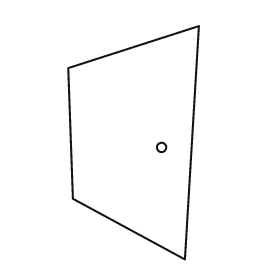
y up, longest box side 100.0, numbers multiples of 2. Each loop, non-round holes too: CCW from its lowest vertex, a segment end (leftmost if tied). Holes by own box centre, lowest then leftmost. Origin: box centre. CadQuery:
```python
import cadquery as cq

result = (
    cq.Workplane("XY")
    .moveTo(22.0, -50.0)
    .lineTo(28.0, 50.0)
    .lineTo(-28.0, 32.0)
    .lineTo(-26.0, -24.0)
    .close()
    .moveTo(12.0, -2.0)
    .circle(2.0)
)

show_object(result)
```